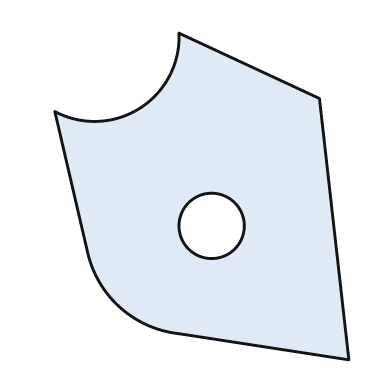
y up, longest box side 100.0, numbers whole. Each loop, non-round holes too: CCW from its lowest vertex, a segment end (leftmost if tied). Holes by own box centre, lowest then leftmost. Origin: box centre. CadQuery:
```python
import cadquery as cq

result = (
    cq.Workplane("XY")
    .moveTo(45.0, -50.0)
    .lineTo(36.0, 30.0)
    .lineTo(-7.0, 50.0)
    .threePointArc((-19.0, 27.0), (-45.0, 26.0))
    .lineTo(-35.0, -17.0)
    .threePointArc((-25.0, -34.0), (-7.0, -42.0))
    .close()
    .moveTo(3.0, -9.0)
    .circle(10.0)
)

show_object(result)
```